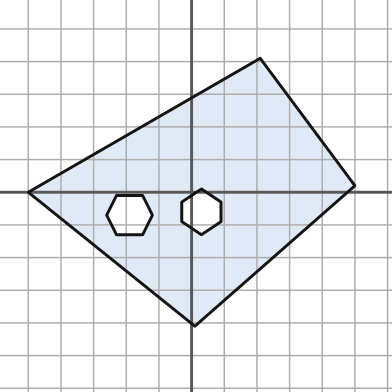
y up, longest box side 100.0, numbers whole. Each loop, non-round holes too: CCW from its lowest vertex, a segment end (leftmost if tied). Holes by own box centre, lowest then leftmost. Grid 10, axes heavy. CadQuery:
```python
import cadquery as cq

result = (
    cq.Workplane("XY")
    .moveTo(1.0, -41.0)
    .lineTo(50.0, 2.0)
    .lineTo(21.0, 41.0)
    .lineTo(-50.0, 0.0)
    .close()
    .moveTo(-23.0, -13.0)
    .lineTo(-15.0, -13.0)
    .lineTo(-12.0, -7.0)
    .lineTo(-15.0, -1.0)
    .lineTo(-23.0, -1.0)
    .lineTo(-26.0, -7.0)
    .close()
    .moveTo(3.0, -13.0)
    .lineTo(9.0, -9.0)
    .lineTo(9.0, -3.0)
    .lineTo(3.0, 1.0)
    .lineTo(-3.0, -3.0)
    .lineTo(-3.0, -9.0)
    .close()
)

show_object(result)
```